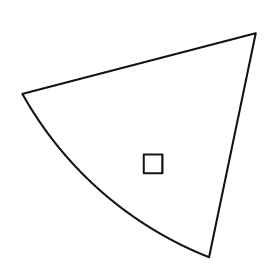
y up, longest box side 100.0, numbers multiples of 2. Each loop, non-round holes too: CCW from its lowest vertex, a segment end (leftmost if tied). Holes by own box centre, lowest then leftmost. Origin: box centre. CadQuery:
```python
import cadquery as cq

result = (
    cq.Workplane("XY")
    .moveTo(30.0, -48.0)
    .lineTo(50.0, 48.0)
    .lineTo(-50.0, 22.0)
    .threePointArc((-16.0, -20.0), (30.0, -48.0))
    .close()
    .moveTo(2.0, -12.0)
    .lineTo(10.0, -12.0)
    .lineTo(10.0, -4.0)
    .lineTo(2.0, -4.0)
    .close()
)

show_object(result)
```